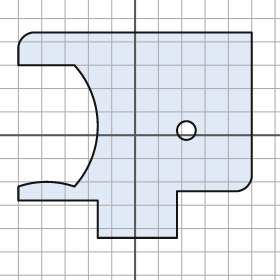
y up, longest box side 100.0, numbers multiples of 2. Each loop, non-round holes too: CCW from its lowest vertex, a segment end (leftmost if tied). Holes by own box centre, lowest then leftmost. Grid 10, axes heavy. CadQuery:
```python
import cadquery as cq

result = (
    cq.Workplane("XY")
    .moveTo(-16.0, -44.0)
    .lineTo(18.0, -44.0)
    .lineTo(18.0, -24.0)
    .lineTo(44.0, -24.0)
    .threePointArc((48.0, -22.0), (50.0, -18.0))
    .lineTo(50.0, 44.0)
    .lineTo(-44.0, 44.0)
    .threePointArc((-48.0, 42.0), (-50.0, 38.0))
    .lineTo(-50.0, 30.0)
    .lineTo(-26.0, 30.0)
    .threePointArc((-16.0, 4.0), (-26.0, -22.0))
    .threePointArc((-38.0, -20.0), (-50.0, -22.0))
    .lineTo(-50.0, -28.0)
    .lineTo(-16.0, -28.0)
    .close()
    .moveTo(22.0, 2.0)
    .circle(4.0)
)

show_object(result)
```